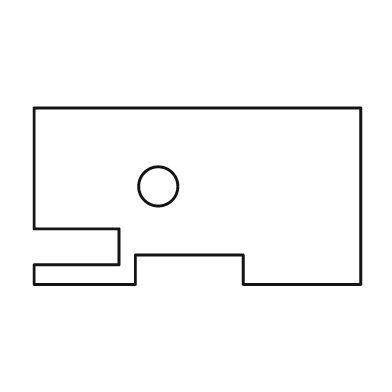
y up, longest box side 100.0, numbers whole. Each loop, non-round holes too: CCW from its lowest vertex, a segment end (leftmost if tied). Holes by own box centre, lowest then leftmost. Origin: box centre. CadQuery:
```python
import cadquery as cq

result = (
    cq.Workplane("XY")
    .moveTo(-50.0, -27.0)
    .lineTo(-19.0, -27.0)
    .lineTo(-19.0, -18.0)
    .lineTo(14.0, -18.0)
    .lineTo(14.0, -27.0)
    .lineTo(50.0, -27.0)
    .lineTo(50.0, 27.0)
    .lineTo(-50.0, 27.0)
    .lineTo(-50.0, -10.0)
    .lineTo(-24.0, -10.0)
    .lineTo(-24.0, -21.0)
    .lineTo(-50.0, -21.0)
    .close()
    .moveTo(-12.0, 3.0)
    .circle(6.0)
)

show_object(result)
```